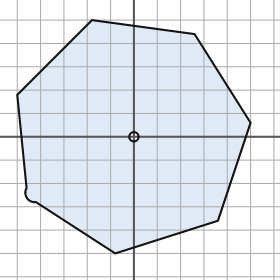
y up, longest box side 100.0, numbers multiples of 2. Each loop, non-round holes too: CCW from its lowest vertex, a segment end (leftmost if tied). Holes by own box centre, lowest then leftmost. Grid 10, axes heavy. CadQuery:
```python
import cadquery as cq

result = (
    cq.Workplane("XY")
    .moveTo(-8.0, -50.0)
    .lineTo(36.0, -36.0)
    .lineTo(50.0, 6.0)
    .lineTo(26.0, 44.0)
    .lineTo(-18.0, 50.0)
    .lineTo(-50.0, 18.0)
    .lineTo(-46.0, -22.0)
    .threePointArc((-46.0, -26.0), (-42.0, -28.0))
    .close()
    .moveTo(0.0, 0.0)
    .circle(2.0)
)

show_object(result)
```